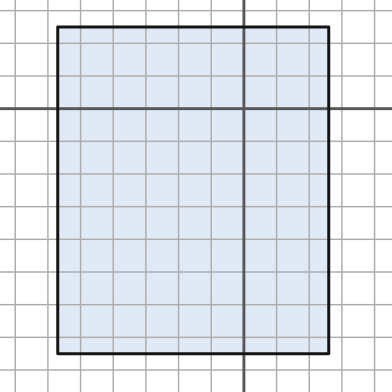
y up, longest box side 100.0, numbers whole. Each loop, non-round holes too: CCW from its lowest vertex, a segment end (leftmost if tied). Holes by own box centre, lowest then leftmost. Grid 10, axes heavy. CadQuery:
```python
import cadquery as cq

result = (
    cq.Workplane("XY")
    .moveTo(-57.0, -75.0)
    .lineTo(26.0, -75.0)
    .lineTo(26.0, 25.0)
    .lineTo(-57.0, 25.0)
    .close()
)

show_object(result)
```